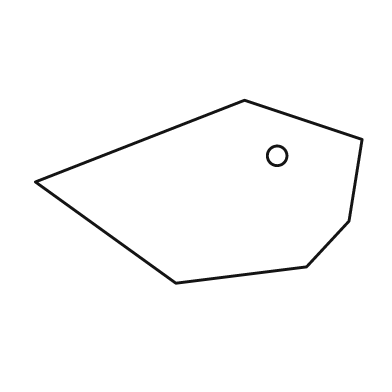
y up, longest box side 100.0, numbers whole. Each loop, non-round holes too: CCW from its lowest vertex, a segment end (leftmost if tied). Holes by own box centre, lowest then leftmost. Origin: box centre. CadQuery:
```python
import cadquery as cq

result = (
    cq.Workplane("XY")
    .moveTo(-7.0, -28.0)
    .lineTo(33.0, -23.0)
    .lineTo(46.0, -9.0)
    .lineTo(50.0, 16.0)
    .lineTo(14.0, 28.0)
    .lineTo(-50.0, 3.0)
    .close()
    .moveTo(24.0, 11.0)
    .circle(3.0)
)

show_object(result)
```